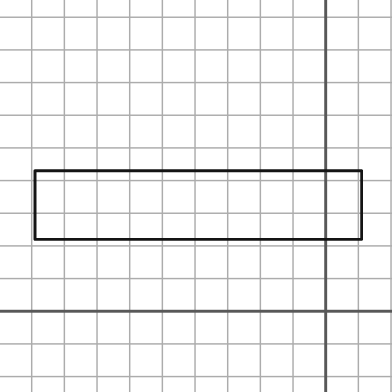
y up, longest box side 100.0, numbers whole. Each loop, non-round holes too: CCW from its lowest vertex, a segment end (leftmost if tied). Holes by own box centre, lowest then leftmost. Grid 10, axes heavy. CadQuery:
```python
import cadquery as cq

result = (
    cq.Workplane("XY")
    .moveTo(-89.0, 22.0)
    .lineTo(11.0, 22.0)
    .lineTo(11.0, 43.0)
    .lineTo(-89.0, 43.0)
    .close()
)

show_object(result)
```